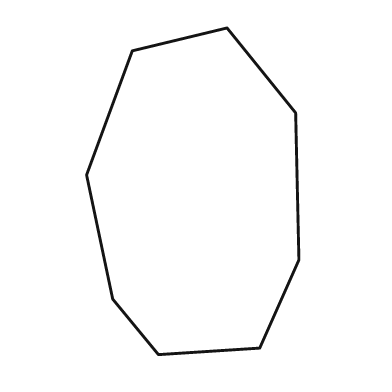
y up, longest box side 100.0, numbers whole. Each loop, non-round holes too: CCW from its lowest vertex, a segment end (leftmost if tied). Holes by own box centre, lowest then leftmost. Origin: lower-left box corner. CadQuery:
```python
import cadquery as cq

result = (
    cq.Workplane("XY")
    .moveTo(22.0, 0.0)
    .lineTo(53.0, 2.0)
    .lineTo(65.0, 29.0)
    .lineTo(64.0, 74.0)
    .lineTo(43.0, 100.0)
    .lineTo(14.0, 93.0)
    .lineTo(0.0, 55.0)
    .lineTo(8.0, 17.0)
    .close()
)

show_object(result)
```